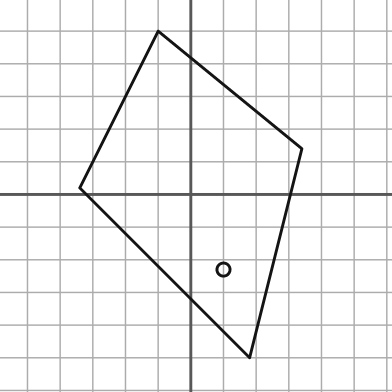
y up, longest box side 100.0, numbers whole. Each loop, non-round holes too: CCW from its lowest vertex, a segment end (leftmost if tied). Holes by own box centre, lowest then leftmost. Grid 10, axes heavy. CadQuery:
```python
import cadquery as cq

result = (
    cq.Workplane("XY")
    .moveTo(18.0, -50.0)
    .lineTo(34.0, 14.0)
    .lineTo(-10.0, 50.0)
    .lineTo(-34.0, 2.0)
    .close()
    .moveTo(10.0, -23.0)
    .circle(2.0)
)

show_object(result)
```